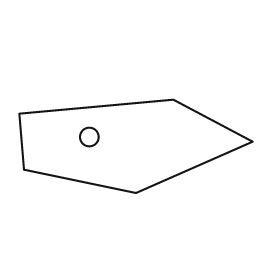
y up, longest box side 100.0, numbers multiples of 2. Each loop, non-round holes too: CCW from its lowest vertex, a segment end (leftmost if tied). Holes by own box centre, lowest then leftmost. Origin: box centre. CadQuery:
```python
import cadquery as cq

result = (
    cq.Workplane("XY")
    .moveTo(0.0, -20.0)
    .lineTo(50.0, 2.0)
    .lineTo(16.0, 20.0)
    .lineTo(-50.0, 14.0)
    .lineTo(-48.0, -10.0)
    .close()
    .moveTo(-20.0, 4.0)
    .circle(4.0)
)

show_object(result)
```